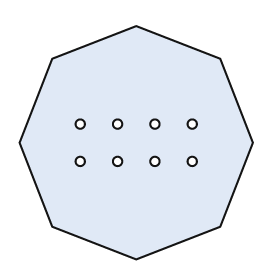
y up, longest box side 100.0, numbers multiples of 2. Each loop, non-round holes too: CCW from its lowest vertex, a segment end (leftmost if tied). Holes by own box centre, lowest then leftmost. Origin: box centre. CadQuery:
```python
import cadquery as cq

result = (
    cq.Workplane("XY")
    .moveTo(0.0, -50.0)
    .lineTo(36.0, -36.0)
    .lineTo(50.0, 0.0)
    .lineTo(36.0, 36.0)
    .lineTo(0.0, 50.0)
    .lineTo(-36.0, 36.0)
    .lineTo(-50.0, 0.0)
    .lineTo(-36.0, -36.0)
    .close()
    .moveTo(-24.0, -8.0)
    .circle(2.0)
    .moveTo(-8.0, -8.0)
    .circle(2.0)
    .moveTo(8.0, -8.0)
    .circle(2.0)
    .moveTo(24.0, -8.0)
    .circle(2.0)
    .moveTo(-24.0, 8.0)
    .circle(2.0)
    .moveTo(-8.0, 8.0)
    .circle(2.0)
    .moveTo(8.0, 8.0)
    .circle(2.0)
    .moveTo(24.0, 8.0)
    .circle(2.0)
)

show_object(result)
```